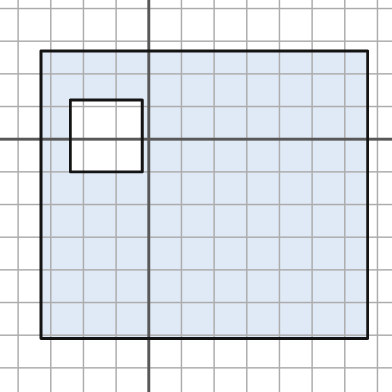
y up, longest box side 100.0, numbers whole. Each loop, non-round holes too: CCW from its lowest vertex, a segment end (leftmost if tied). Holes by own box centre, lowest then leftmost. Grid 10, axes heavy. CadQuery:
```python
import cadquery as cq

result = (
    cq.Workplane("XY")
    .moveTo(-33.0, -61.0)
    .lineTo(67.0, -61.0)
    .lineTo(67.0, 27.0)
    .lineTo(-33.0, 27.0)
    .close()
    .moveTo(-24.0, -10.0)
    .lineTo(-2.0, -10.0)
    .lineTo(-2.0, 12.0)
    .lineTo(-24.0, 12.0)
    .close()
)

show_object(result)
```